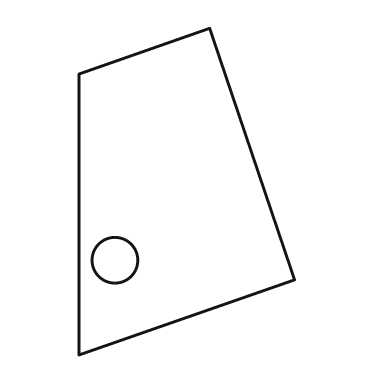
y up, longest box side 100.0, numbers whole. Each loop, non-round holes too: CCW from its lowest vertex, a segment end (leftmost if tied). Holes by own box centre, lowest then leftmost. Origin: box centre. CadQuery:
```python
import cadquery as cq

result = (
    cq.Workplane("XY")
    .moveTo(-33.0, -50.0)
    .lineTo(33.0, -27.0)
    .lineTo(7.0, 50.0)
    .lineTo(-33.0, 36.0)
    .close()
    .moveTo(-22.0, -21.0)
    .circle(7.0)
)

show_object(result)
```